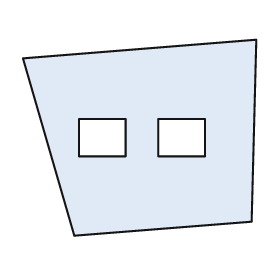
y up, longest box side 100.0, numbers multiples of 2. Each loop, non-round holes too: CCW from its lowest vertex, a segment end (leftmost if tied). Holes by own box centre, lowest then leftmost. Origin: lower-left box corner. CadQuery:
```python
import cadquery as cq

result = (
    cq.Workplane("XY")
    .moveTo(22.0, 0.0)
    .lineTo(98.0, 6.0)
    .lineTo(100.0, 84.0)
    .lineTo(0.0, 76.0)
    .close()
    .moveTo(24.0, 34.0)
    .lineTo(44.0, 34.0)
    .lineTo(44.0, 50.0)
    .lineTo(24.0, 50.0)
    .close()
    .moveTo(58.0, 34.0)
    .lineTo(78.0, 34.0)
    .lineTo(78.0, 50.0)
    .lineTo(58.0, 50.0)
    .close()
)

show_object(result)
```